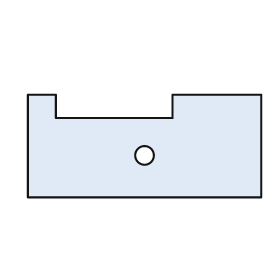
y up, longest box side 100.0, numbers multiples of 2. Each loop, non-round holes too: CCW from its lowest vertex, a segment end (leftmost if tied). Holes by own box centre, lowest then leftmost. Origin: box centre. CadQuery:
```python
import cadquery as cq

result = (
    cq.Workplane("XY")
    .moveTo(-50.0, -22.0)
    .lineTo(50.0, -22.0)
    .lineTo(50.0, 22.0)
    .lineTo(12.0, 22.0)
    .lineTo(12.0, 12.0)
    .lineTo(-38.0, 12.0)
    .lineTo(-38.0, 22.0)
    .lineTo(-50.0, 22.0)
    .close()
    .moveTo(0.0, -4.0)
    .circle(4.0)
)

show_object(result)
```